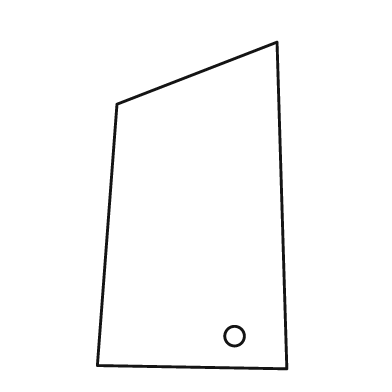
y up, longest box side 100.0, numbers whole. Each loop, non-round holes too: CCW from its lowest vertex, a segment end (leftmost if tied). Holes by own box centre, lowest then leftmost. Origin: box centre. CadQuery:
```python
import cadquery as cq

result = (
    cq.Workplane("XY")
    .moveTo(29.0, -50.0)
    .lineTo(26.0, 50.0)
    .lineTo(-23.0, 31.0)
    .lineTo(-29.0, -49.0)
    .close()
    .moveTo(13.0, -40.0)
    .circle(3.0)
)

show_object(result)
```